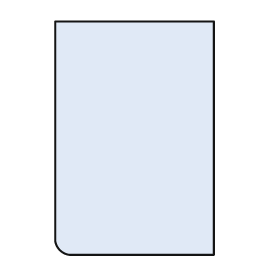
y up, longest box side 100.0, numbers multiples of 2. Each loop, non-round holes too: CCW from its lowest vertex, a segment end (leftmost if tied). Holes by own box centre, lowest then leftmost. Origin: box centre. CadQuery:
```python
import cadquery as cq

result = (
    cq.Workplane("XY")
    .moveTo(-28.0, -50.0)
    .lineTo(34.0, -50.0)
    .lineTo(34.0, 50.0)
    .lineTo(-34.0, 50.0)
    .lineTo(-34.0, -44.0)
    .threePointArc((-32.0, -48.0), (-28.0, -50.0))
    .close()
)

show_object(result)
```